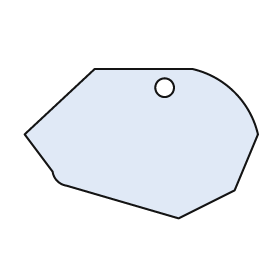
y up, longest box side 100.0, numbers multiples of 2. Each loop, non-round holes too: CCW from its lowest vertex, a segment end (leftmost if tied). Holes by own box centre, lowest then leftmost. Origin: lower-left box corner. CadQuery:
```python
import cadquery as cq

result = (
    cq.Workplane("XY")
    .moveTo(66.0, 0.0)
    .lineTo(90.0, 12.0)
    .lineTo(100.0, 36.0)
    .threePointArc((90.0, 54.0), (72.0, 64.0))
    .lineTo(30.0, 64.0)
    .lineTo(0.0, 36.0)
    .lineTo(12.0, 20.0)
    .threePointArc((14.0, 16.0), (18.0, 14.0))
    .close()
    .moveTo(60.0, 56.0)
    .circle(4.0)
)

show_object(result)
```